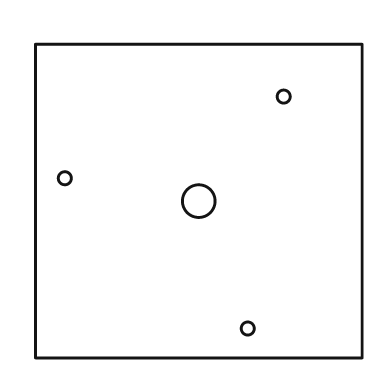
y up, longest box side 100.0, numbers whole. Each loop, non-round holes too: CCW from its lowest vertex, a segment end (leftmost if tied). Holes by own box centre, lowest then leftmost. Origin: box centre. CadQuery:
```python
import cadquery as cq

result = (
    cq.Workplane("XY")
    .moveTo(-50.0, -48.0)
    .lineTo(50.0, -48.0)
    .lineTo(50.0, 48.0)
    .lineTo(-50.0, 48.0)
    .close()
    .moveTo(15.0, -39.0)
    .circle(2.0)
    .moveTo(0.0, 0.0)
    .circle(5.0)
    .moveTo(-41.0, 7.0)
    .circle(2.0)
    .moveTo(26.0, 32.0)
    .circle(2.0)
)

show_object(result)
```